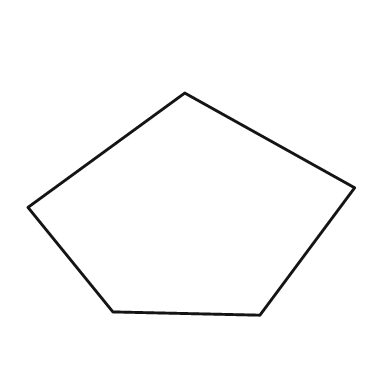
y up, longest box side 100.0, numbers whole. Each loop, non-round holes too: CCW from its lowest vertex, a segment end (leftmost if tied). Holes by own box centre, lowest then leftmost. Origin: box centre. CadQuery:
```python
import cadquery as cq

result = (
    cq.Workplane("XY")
    .moveTo(21.0, -34.0)
    .lineTo(50.0, 5.0)
    .lineTo(-2.0, 34.0)
    .lineTo(-50.0, -1.0)
    .lineTo(-24.0, -33.0)
    .close()
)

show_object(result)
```